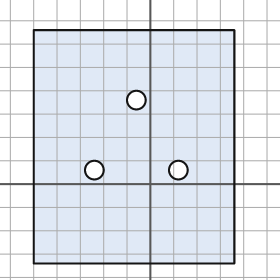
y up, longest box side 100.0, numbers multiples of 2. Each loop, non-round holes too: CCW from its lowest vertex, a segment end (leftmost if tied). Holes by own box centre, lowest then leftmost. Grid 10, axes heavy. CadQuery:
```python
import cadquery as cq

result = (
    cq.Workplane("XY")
    .moveTo(-50.0, -34.0)
    .lineTo(36.0, -34.0)
    .lineTo(36.0, 66.0)
    .lineTo(-50.0, 66.0)
    .close()
    .moveTo(-24.0, 6.0)
    .circle(4.0)
    .moveTo(12.0, 6.0)
    .circle(4.0)
    .moveTo(-6.0, 36.0)
    .circle(4.0)
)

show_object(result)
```